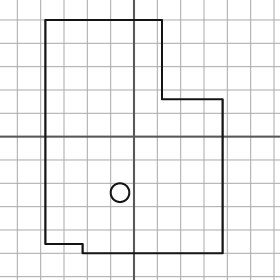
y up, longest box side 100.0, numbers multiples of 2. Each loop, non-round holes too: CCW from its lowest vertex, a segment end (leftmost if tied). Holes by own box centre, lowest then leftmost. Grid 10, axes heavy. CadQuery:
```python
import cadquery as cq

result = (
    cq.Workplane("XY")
    .moveTo(-22.0, -50.0)
    .lineTo(38.0, -50.0)
    .lineTo(38.0, 16.0)
    .lineTo(12.0, 16.0)
    .lineTo(12.0, 50.0)
    .lineTo(-38.0, 50.0)
    .lineTo(-38.0, -46.0)
    .lineTo(-22.0, -46.0)
    .close()
    .moveTo(-6.0, -24.0)
    .circle(4.0)
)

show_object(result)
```